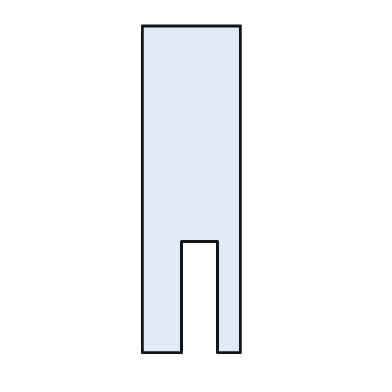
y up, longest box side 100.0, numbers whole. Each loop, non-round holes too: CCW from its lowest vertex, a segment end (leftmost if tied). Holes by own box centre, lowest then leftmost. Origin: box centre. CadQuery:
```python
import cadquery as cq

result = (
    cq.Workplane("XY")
    .moveTo(-15.0, -50.0)
    .lineTo(-3.0, -50.0)
    .lineTo(-3.0, -16.0)
    .lineTo(8.0, -16.0)
    .lineTo(8.0, -50.0)
    .lineTo(15.0, -50.0)
    .lineTo(15.0, 50.0)
    .lineTo(-15.0, 50.0)
    .close()
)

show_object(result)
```